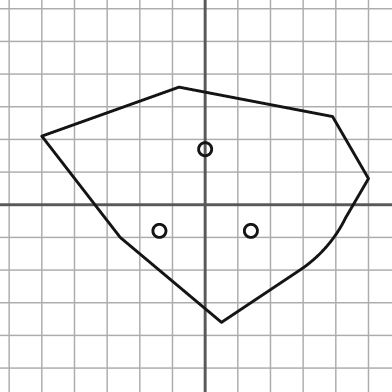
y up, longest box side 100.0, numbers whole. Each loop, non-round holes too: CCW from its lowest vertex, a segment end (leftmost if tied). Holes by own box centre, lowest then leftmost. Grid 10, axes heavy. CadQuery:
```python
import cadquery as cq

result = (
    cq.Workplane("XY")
    .moveTo(5.0, -36.0)
    .lineTo(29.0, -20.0)
    .threePointArc((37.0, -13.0), (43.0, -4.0))
    .lineTo(50.0, 8.0)
    .lineTo(39.0, 27.0)
    .lineTo(-8.0, 36.0)
    .lineTo(-50.0, 21.0)
    .lineTo(-26.0, -10.0)
    .close()
    .moveTo(-14.0, -8.0)
    .circle(2.0)
    .moveTo(14.0, -8.0)
    .circle(2.0)
    .moveTo(0.0, 17.0)
    .circle(2.0)
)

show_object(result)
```